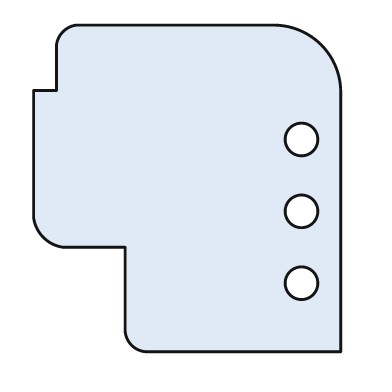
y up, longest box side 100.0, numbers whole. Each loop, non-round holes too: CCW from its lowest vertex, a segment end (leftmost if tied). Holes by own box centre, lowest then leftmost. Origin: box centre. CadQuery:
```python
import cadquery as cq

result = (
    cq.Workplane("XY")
    .moveTo(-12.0, -50.0)
    .lineTo(47.0, -50.0)
    .lineTo(47.0, 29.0)
    .threePointArc((41.0, 44.0), (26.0, 50.0))
    .lineTo(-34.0, 50.0)
    .threePointArc((-38.0, 48.0), (-40.0, 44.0))
    .lineTo(-40.0, 30.0)
    .lineTo(-47.0, 30.0)
    .lineTo(-47.0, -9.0)
    .threePointArc((-44.0, -15.0), (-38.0, -18.0))
    .lineTo(-19.0, -18.0)
    .lineTo(-19.0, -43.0)
    .threePointArc((-17.0, -48.0), (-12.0, -50.0))
    .close()
    .moveTo(35.0, -29.0)
    .circle(5.0)
    .moveTo(35.0, -7.0)
    .circle(5.0)
    .moveTo(35.0, 15.0)
    .circle(5.0)
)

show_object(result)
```